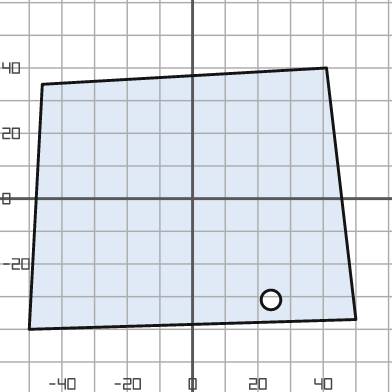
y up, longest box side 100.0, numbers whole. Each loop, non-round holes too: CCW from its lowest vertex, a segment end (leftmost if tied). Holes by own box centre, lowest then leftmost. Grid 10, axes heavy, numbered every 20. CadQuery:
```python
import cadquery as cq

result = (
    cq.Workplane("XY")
    .moveTo(-50.0, -40.0)
    .lineTo(50.0, -37.0)
    .lineTo(41.0, 40.0)
    .lineTo(-46.0, 35.0)
    .close()
    .moveTo(24.0, -31.0)
    .circle(3.0)
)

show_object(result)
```